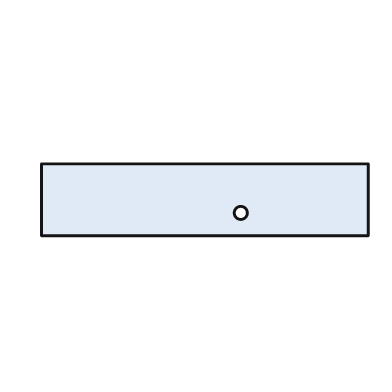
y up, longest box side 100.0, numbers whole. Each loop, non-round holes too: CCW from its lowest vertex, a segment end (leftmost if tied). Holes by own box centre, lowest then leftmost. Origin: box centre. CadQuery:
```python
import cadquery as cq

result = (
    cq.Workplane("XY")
    .moveTo(-50.0, -11.0)
    .lineTo(50.0, -11.0)
    .lineTo(50.0, 11.0)
    .lineTo(-50.0, 11.0)
    .close()
    .moveTo(11.0, -4.0)
    .circle(2.0)
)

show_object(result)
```